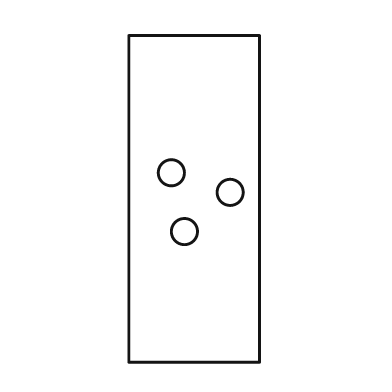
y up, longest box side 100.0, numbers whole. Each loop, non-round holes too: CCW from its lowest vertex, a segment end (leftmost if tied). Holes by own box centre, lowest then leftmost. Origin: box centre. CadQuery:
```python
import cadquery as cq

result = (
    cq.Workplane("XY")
    .moveTo(-20.0, -50.0)
    .lineTo(20.0, -50.0)
    .lineTo(20.0, 50.0)
    .lineTo(-20.0, 50.0)
    .close()
    .moveTo(-3.0, -10.0)
    .circle(4.0)
    .moveTo(11.0, 2.0)
    .circle(4.0)
    .moveTo(-7.0, 8.0)
    .circle(4.0)
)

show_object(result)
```